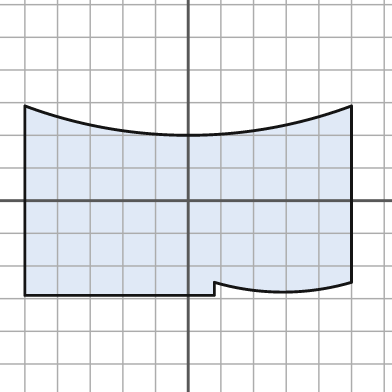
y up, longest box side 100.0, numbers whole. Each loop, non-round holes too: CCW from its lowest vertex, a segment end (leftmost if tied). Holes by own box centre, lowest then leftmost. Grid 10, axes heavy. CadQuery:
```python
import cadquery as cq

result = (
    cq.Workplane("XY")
    .moveTo(-50.0, -29.0)
    .lineTo(8.0, -29.0)
    .lineTo(8.0, -25.0)
    .threePointArc((29.0, -28.0), (50.0, -25.0))
    .lineTo(50.0, 29.0)
    .threePointArc((0.0, 20.0), (-50.0, 29.0))
    .close()
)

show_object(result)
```